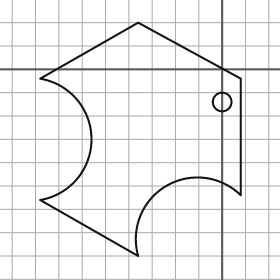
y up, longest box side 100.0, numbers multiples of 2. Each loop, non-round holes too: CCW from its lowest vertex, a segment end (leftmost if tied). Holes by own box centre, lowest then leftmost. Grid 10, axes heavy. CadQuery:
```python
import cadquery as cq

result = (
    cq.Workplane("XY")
    .moveTo(-36.0, -80.0)
    .threePointArc((-24.0, -50.0), (8.0, -54.0))
    .lineTo(8.0, -4.0)
    .lineTo(-36.0, 20.0)
    .lineTo(-78.0, -4.0)
    .threePointArc((-56.0, -30.0), (-78.0, -56.0))
    .close()
    .moveTo(0.0, -14.0)
    .circle(4.0)
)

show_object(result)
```